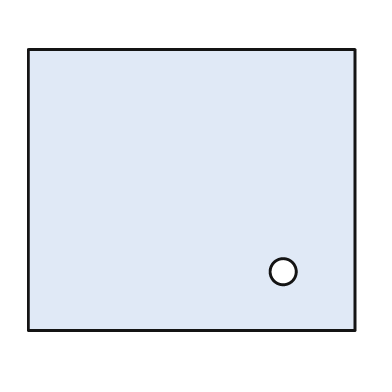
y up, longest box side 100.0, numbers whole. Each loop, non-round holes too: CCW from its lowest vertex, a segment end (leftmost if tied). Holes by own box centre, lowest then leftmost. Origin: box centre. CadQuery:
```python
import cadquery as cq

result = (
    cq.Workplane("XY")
    .moveTo(-50.0, -43.0)
    .lineTo(50.0, -43.0)
    .lineTo(50.0, 43.0)
    .lineTo(-50.0, 43.0)
    .close()
    .moveTo(28.0, -25.0)
    .circle(4.0)
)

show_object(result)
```